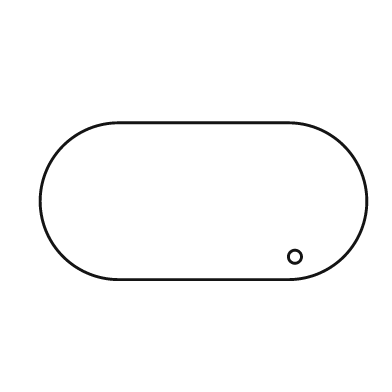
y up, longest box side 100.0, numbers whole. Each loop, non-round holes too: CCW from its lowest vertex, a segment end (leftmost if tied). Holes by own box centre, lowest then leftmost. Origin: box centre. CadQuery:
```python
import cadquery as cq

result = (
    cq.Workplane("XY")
    .moveTo(-26.0, -24.0)
    .lineTo(26.0, -24.0)
    .threePointArc((50.0, 0.0), (26.0, 24.0))
    .lineTo(-26.0, 24.0)
    .threePointArc((-50.0, 0.0), (-26.0, -24.0))
    .close()
    .moveTo(28.0, -17.0)
    .circle(2.0)
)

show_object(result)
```